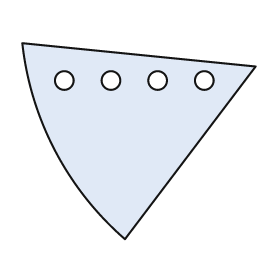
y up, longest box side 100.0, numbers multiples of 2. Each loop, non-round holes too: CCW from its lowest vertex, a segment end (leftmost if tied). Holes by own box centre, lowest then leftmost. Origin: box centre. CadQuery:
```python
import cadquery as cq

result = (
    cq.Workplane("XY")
    .moveTo(-6.0, -42.0)
    .lineTo(50.0, 32.0)
    .lineTo(-50.0, 42.0)
    .threePointArc((-36.0, -4.0), (-6.0, -42.0))
    .close()
    .moveTo(-32.0, 26.0)
    .circle(4.0)
    .moveTo(-12.0, 26.0)
    .circle(4.0)
    .moveTo(8.0, 26.0)
    .circle(4.0)
    .moveTo(28.0, 26.0)
    .circle(4.0)
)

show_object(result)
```